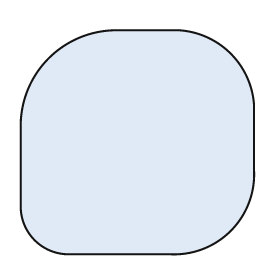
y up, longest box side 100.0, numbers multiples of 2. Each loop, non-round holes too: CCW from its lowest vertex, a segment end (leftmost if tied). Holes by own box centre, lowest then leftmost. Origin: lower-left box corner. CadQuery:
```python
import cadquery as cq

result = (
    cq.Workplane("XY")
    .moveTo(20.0, 0.0)
    .lineTo(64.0, 0.0)
    .threePointArc((90.0, 10.0), (100.0, 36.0))
    .lineTo(100.0, 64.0)
    .threePointArc((90.0, 86.0), (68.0, 96.0))
    .lineTo(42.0, 96.0)
    .threePointArc((12.0, 84.0), (0.0, 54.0))
    .lineTo(0.0, 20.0)
    .threePointArc((6.0, 6.0), (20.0, 0.0))
    .close()
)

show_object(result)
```